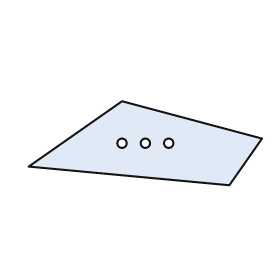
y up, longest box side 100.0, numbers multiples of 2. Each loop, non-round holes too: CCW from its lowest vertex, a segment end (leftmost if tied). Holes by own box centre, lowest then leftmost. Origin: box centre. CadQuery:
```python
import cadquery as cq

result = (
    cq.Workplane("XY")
    .moveTo(36.0, -18.0)
    .lineTo(50.0, 2.0)
    .lineTo(-10.0, 18.0)
    .lineTo(-50.0, -10.0)
    .close()
    .moveTo(-10.0, 0.0)
    .circle(2.0)
    .moveTo(0.0, 0.0)
    .circle(2.0)
    .moveTo(10.0, 0.0)
    .circle(2.0)
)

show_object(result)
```